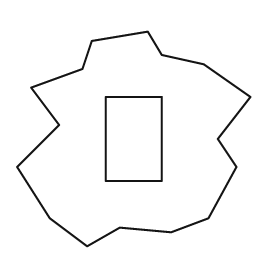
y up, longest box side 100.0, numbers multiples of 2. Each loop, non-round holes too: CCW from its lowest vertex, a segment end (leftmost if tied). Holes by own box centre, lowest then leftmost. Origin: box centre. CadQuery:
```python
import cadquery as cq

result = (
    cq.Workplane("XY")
    .moveTo(-20.0, -46.0)
    .lineTo(-6.0, -38.0)
    .lineTo(16.0, -40.0)
    .lineTo(32.0, -34.0)
    .lineTo(44.0, -12.0)
    .lineTo(36.0, 0.0)
    .lineTo(50.0, 18.0)
    .lineTo(30.0, 32.0)
    .lineTo(12.0, 36.0)
    .lineTo(6.0, 46.0)
    .lineTo(-18.0, 42.0)
    .lineTo(-22.0, 30.0)
    .lineTo(-44.0, 22.0)
    .lineTo(-32.0, 6.0)
    .lineTo(-50.0, -12.0)
    .lineTo(-36.0, -34.0)
    .close()
    .moveTo(-12.0, -18.0)
    .lineTo(12.0, -18.0)
    .lineTo(12.0, 18.0)
    .lineTo(-12.0, 18.0)
    .close()
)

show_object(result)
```